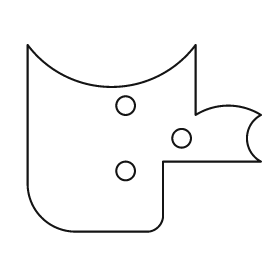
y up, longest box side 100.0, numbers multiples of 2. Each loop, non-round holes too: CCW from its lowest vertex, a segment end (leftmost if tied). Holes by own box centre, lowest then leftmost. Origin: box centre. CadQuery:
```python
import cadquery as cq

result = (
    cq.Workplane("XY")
    .moveTo(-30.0, -40.0)
    .lineTo(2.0, -40.0)
    .threePointArc((6.0, -38.0), (8.0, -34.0))
    .lineTo(8.0, -10.0)
    .lineTo(50.0, -10.0)
    .threePointArc((44.0, 0.0), (50.0, 10.0))
    .threePointArc((36.0, 14.0), (22.0, 10.0))
    .lineTo(22.0, 40.0)
    .threePointArc((-14.0, 22.0), (-50.0, 40.0))
    .lineTo(-50.0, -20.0)
    .threePointArc((-44.0, -34.0), (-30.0, -40.0))
    .close()
    .moveTo(-8.0, -14.0)
    .circle(4.0)
    .moveTo(16.0, 0.0)
    .circle(4.0)
    .moveTo(-8.0, 14.0)
    .circle(4.0)
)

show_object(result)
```